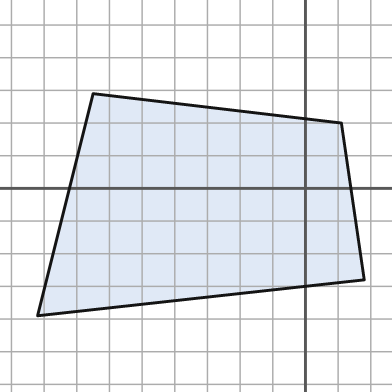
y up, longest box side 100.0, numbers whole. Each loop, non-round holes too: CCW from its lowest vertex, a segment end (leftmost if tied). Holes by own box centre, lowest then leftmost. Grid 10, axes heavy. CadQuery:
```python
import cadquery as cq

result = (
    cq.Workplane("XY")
    .moveTo(-82.0, -39.0)
    .lineTo(18.0, -28.0)
    .lineTo(11.0, 20.0)
    .lineTo(-65.0, 29.0)
    .close()
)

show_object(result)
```